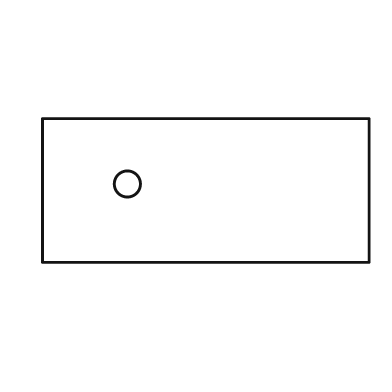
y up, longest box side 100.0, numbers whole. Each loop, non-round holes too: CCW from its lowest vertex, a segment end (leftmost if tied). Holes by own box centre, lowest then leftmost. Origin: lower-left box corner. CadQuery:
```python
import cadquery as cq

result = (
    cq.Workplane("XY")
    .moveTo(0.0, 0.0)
    .lineTo(100.0, 0.0)
    .lineTo(100.0, 44.0)
    .lineTo(0.0, 44.0)
    .close()
    .moveTo(26.0, 24.0)
    .circle(4.0)
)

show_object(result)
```